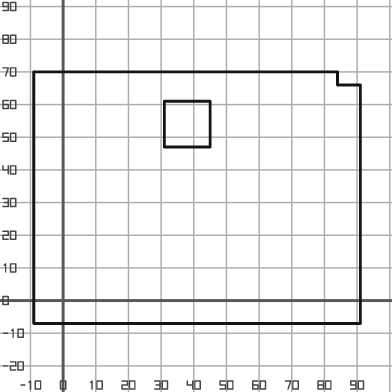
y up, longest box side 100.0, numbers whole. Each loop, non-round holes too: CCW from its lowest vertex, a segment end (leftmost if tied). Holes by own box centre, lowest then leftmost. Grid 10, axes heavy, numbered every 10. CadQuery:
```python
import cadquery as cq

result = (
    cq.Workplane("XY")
    .moveTo(-9.0, -7.0)
    .lineTo(91.0, -7.0)
    .lineTo(91.0, 66.0)
    .lineTo(84.0, 66.0)
    .lineTo(84.0, 70.0)
    .lineTo(-9.0, 70.0)
    .close()
    .moveTo(31.0, 47.0)
    .lineTo(45.0, 47.0)
    .lineTo(45.0, 61.0)
    .lineTo(31.0, 61.0)
    .close()
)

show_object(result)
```